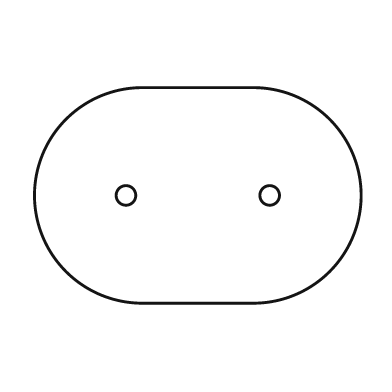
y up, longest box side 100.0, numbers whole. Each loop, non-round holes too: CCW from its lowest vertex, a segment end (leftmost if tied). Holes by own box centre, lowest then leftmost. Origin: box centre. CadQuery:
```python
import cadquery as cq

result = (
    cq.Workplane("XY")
    .moveTo(-17.0, -33.0)
    .lineTo(17.0, -33.0)
    .threePointArc((50.0, 0.0), (17.0, 33.0))
    .lineTo(-17.0, 33.0)
    .threePointArc((-50.0, 0.0), (-17.0, -33.0))
    .close()
    .moveTo(-22.0, 0.0)
    .circle(3.0)
    .moveTo(22.0, 0.0)
    .circle(3.0)
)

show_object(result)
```